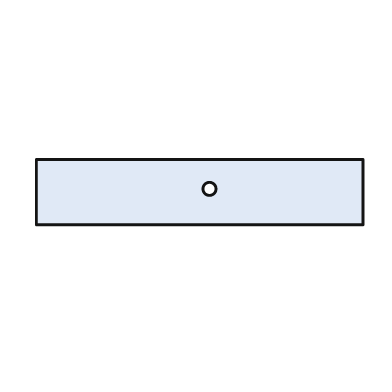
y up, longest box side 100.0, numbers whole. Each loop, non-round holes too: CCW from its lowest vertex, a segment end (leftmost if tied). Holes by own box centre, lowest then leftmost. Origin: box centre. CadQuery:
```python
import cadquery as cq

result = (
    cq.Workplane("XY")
    .moveTo(-50.0, -10.0)
    .lineTo(50.0, -10.0)
    .lineTo(50.0, 10.0)
    .lineTo(-50.0, 10.0)
    .close()
    .moveTo(3.0, 1.0)
    .circle(2.0)
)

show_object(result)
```